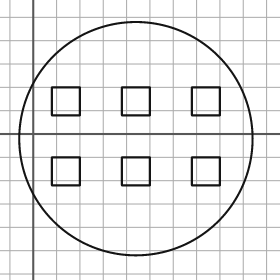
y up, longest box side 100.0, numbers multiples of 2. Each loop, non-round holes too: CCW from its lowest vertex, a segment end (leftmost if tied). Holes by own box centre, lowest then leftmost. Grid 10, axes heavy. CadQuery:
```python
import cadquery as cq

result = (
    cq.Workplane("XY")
    .moveTo(44.0, -2.0)
    .circle(50.0)
    .moveTo(8.0, -22.0)
    .lineTo(20.0, -22.0)
    .lineTo(20.0, -10.0)
    .lineTo(8.0, -10.0)
    .close()
    .moveTo(38.0, -22.0)
    .lineTo(50.0, -22.0)
    .lineTo(50.0, -10.0)
    .lineTo(38.0, -10.0)
    .close()
    .moveTo(68.0, -22.0)
    .lineTo(80.0, -22.0)
    .lineTo(80.0, -10.0)
    .lineTo(68.0, -10.0)
    .close()
    .moveTo(8.0, 8.0)
    .lineTo(20.0, 8.0)
    .lineTo(20.0, 20.0)
    .lineTo(8.0, 20.0)
    .close()
    .moveTo(38.0, 8.0)
    .lineTo(50.0, 8.0)
    .lineTo(50.0, 20.0)
    .lineTo(38.0, 20.0)
    .close()
    .moveTo(68.0, 8.0)
    .lineTo(80.0, 8.0)
    .lineTo(80.0, 20.0)
    .lineTo(68.0, 20.0)
    .close()
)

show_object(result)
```